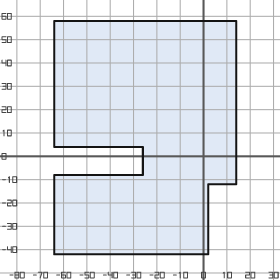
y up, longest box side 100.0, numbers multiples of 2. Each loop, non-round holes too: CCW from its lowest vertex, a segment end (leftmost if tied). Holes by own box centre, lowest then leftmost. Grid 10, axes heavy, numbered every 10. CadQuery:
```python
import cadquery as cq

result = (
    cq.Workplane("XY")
    .moveTo(-64.0, -42.0)
    .lineTo(2.0, -42.0)
    .lineTo(2.0, -12.0)
    .lineTo(14.0, -12.0)
    .lineTo(14.0, 58.0)
    .lineTo(-64.0, 58.0)
    .lineTo(-64.0, 4.0)
    .lineTo(-26.0, 4.0)
    .lineTo(-26.0, -8.0)
    .lineTo(-64.0, -8.0)
    .close()
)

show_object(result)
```